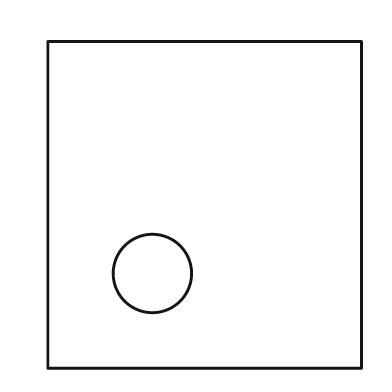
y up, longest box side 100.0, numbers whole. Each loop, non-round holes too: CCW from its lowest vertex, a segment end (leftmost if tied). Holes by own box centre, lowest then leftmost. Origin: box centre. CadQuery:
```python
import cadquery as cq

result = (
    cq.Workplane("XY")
    .moveTo(-48.0, -50.0)
    .lineTo(48.0, -50.0)
    .lineTo(48.0, 50.0)
    .lineTo(-48.0, 50.0)
    .close()
    .moveTo(-16.0, -21.0)
    .circle(12.0)
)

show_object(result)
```